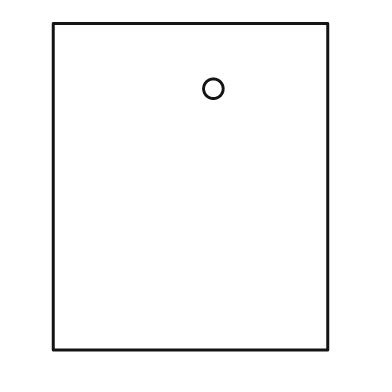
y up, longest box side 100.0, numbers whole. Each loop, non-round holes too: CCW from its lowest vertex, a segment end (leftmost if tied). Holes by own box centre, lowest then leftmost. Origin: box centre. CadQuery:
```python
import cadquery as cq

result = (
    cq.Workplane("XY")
    .moveTo(-42.0, -50.0)
    .lineTo(42.0, -50.0)
    .lineTo(42.0, 50.0)
    .lineTo(-42.0, 50.0)
    .close()
    .moveTo(7.0, 30.0)
    .circle(3.0)
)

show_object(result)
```